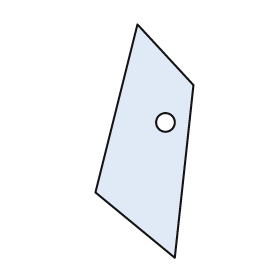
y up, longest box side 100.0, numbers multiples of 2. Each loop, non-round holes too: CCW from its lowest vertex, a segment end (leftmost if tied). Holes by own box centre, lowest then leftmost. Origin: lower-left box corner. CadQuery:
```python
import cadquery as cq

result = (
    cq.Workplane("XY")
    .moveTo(34.0, 0.0)
    .lineTo(42.0, 74.0)
    .lineTo(18.0, 100.0)
    .lineTo(0.0, 28.0)
    .close()
    .moveTo(30.0, 58.0)
    .circle(4.0)
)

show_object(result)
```